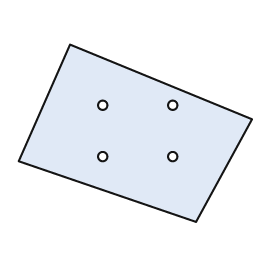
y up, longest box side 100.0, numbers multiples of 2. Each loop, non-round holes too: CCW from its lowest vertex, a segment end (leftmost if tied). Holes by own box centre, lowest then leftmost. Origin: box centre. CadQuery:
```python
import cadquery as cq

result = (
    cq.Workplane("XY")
    .moveTo(26.0, -38.0)
    .lineTo(50.0, 6.0)
    .lineTo(-28.0, 38.0)
    .lineTo(-50.0, -12.0)
    .close()
    .moveTo(-14.0, -10.0)
    .circle(2.0)
    .moveTo(16.0, -10.0)
    .circle(2.0)
    .moveTo(-14.0, 12.0)
    .circle(2.0)
    .moveTo(16.0, 12.0)
    .circle(2.0)
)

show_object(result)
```